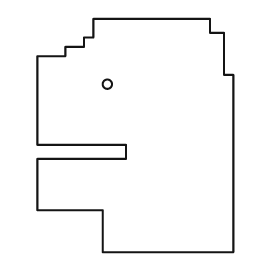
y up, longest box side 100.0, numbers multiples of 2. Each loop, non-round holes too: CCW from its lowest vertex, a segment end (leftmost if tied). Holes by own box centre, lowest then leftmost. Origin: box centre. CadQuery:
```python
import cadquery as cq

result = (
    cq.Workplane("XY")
    .moveTo(-14.0, -50.0)
    .lineTo(42.0, -50.0)
    .lineTo(42.0, 26.0)
    .lineTo(38.0, 26.0)
    .lineTo(38.0, 44.0)
    .lineTo(32.0, 44.0)
    .lineTo(32.0, 50.0)
    .lineTo(-18.0, 50.0)
    .lineTo(-18.0, 42.0)
    .lineTo(-22.0, 42.0)
    .lineTo(-22.0, 38.0)
    .lineTo(-30.0, 38.0)
    .lineTo(-30.0, 34.0)
    .lineTo(-42.0, 34.0)
    .lineTo(-42.0, -4.0)
    .lineTo(-4.0, -4.0)
    .lineTo(-4.0, -10.0)
    .lineTo(-42.0, -10.0)
    .lineTo(-42.0, -32.0)
    .lineTo(-14.0, -32.0)
    .close()
    .moveTo(-12.0, 22.0)
    .circle(2.0)
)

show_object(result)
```